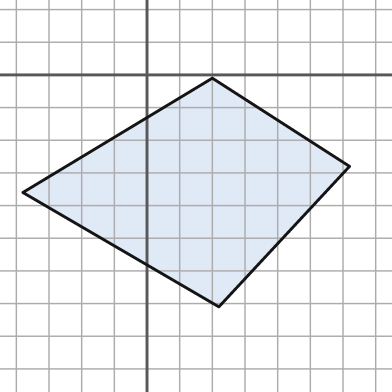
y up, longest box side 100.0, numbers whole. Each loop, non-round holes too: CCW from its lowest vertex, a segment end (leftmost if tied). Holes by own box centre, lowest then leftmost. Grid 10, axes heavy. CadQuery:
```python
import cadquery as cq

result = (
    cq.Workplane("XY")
    .moveTo(22.0, -71.0)
    .lineTo(62.0, -28.0)
    .lineTo(20.0, -1.0)
    .lineTo(-38.0, -36.0)
    .close()
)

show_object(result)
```